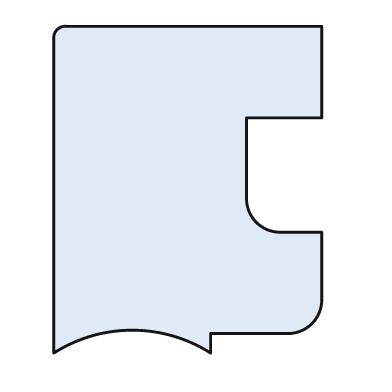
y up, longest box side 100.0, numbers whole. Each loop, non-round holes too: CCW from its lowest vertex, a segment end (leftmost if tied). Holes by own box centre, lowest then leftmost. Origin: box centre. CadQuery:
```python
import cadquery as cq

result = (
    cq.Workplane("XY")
    .moveTo(-41.0, -50.0)
    .threePointArc((-17.0, -43.0), (7.0, -50.0))
    .lineTo(7.0, -44.0)
    .lineTo(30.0, -44.0)
    .threePointArc((38.0, -41.0), (41.0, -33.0))
    .lineTo(41.0, -13.0)
    .lineTo(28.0, -13.0)
    .threePointArc((21.0, -10.0), (18.0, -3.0))
    .lineTo(18.0, 22.0)
    .lineTo(41.0, 22.0)
    .lineTo(41.0, 50.0)
    .lineTo(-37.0, 50.0)
    .threePointArc((-40.0, 49.0), (-41.0, 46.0))
    .close()
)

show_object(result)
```